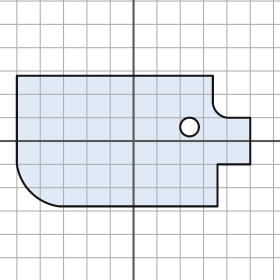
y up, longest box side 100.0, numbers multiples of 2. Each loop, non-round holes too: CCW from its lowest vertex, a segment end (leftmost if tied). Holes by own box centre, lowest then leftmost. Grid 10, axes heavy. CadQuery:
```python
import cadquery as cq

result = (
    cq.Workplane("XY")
    .moveTo(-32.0, -28.0)
    .lineTo(36.0, -28.0)
    .lineTo(36.0, -10.0)
    .lineTo(50.0, -10.0)
    .lineTo(50.0, 10.0)
    .lineTo(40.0, 10.0)
    .threePointArc((36.0, 12.0), (34.0, 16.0))
    .lineTo(34.0, 28.0)
    .lineTo(-50.0, 28.0)
    .lineTo(-50.0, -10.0)
    .threePointArc((-44.0, -22.0), (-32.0, -28.0))
    .close()
    .moveTo(24.0, 6.0)
    .circle(4.0)
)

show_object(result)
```